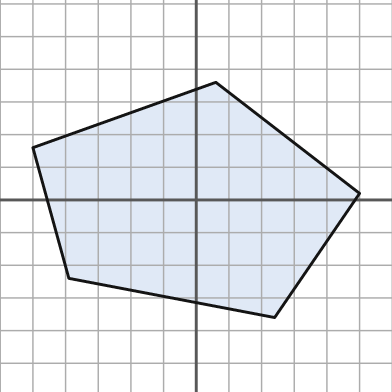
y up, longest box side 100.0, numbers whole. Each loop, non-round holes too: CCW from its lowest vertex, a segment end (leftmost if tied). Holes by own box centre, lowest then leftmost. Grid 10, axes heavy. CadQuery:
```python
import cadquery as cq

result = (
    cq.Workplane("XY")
    .moveTo(24.0, -36.0)
    .lineTo(50.0, 2.0)
    .lineTo(6.0, 36.0)
    .lineTo(-50.0, 16.0)
    .lineTo(-39.0, -24.0)
    .close()
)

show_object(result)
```